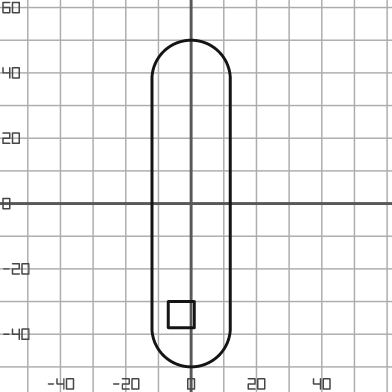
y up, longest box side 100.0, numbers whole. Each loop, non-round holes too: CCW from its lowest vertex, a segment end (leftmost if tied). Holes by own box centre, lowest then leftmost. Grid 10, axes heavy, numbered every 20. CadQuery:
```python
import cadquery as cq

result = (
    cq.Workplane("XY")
    .moveTo(-12.0, -38.0)
    .threePointArc((0.0, -50.0), (12.0, -38.0))
    .lineTo(12.0, 38.0)
    .threePointArc((0.0, 50.0), (-12.0, 38.0))
    .close()
    .moveTo(-7.0, -38.0)
    .lineTo(1.0, -38.0)
    .lineTo(1.0, -30.0)
    .lineTo(-7.0, -30.0)
    .close()
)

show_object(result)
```